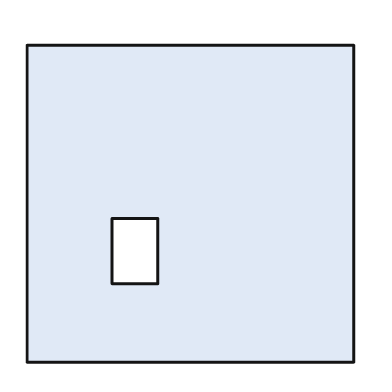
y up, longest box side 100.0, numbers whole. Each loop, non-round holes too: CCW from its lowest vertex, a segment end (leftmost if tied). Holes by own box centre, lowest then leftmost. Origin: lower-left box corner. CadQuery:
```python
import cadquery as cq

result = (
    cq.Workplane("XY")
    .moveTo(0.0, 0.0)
    .lineTo(100.0, 0.0)
    .lineTo(100.0, 97.0)
    .lineTo(0.0, 97.0)
    .close()
    .moveTo(26.0, 24.0)
    .lineTo(40.0, 24.0)
    .lineTo(40.0, 44.0)
    .lineTo(26.0, 44.0)
    .close()
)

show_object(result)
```